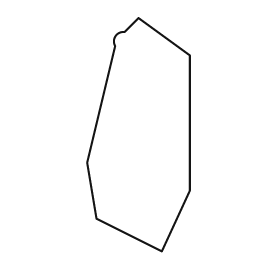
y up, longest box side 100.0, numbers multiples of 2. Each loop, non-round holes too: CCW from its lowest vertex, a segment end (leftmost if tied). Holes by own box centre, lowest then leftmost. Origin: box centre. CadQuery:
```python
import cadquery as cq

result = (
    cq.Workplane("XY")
    .moveTo(10.0, -50.0)
    .lineTo(22.0, -24.0)
    .lineTo(22.0, 34.0)
    .lineTo(0.0, 50.0)
    .lineTo(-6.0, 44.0)
    .threePointArc((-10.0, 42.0), (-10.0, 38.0))
    .lineTo(-22.0, -12.0)
    .lineTo(-18.0, -36.0)
    .close()
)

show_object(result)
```